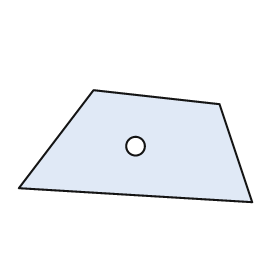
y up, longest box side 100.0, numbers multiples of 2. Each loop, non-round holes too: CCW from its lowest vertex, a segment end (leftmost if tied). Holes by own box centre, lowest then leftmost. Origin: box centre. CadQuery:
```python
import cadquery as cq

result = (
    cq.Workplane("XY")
    .moveTo(50.0, -24.0)
    .lineTo(36.0, 18.0)
    .lineTo(-18.0, 24.0)
    .lineTo(-50.0, -18.0)
    .close()
    .moveTo(0.0, 0.0)
    .circle(4.0)
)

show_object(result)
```